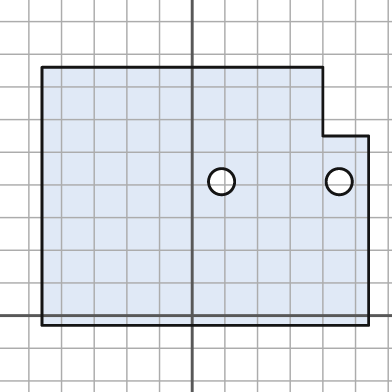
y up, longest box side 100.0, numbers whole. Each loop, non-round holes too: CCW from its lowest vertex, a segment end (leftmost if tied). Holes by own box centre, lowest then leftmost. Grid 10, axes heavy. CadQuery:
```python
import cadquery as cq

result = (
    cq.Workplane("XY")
    .moveTo(-46.0, -3.0)
    .lineTo(54.0, -3.0)
    .lineTo(54.0, 55.0)
    .lineTo(40.0, 55.0)
    .lineTo(40.0, 76.0)
    .lineTo(-46.0, 76.0)
    .close()
    .moveTo(9.0, 41.0)
    .circle(4.0)
    .moveTo(45.0, 41.0)
    .circle(4.0)
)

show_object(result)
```